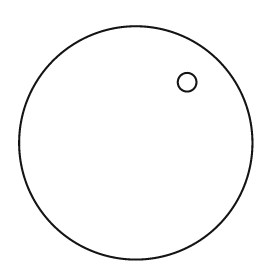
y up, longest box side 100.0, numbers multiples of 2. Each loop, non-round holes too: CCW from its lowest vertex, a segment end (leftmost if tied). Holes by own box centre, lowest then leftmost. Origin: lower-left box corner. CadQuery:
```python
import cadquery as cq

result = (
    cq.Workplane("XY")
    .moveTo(50.0, 50.0)
    .circle(50.0)
    .moveTo(72.0, 76.0)
    .circle(4.0)
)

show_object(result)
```